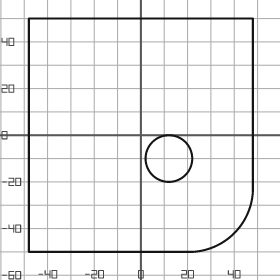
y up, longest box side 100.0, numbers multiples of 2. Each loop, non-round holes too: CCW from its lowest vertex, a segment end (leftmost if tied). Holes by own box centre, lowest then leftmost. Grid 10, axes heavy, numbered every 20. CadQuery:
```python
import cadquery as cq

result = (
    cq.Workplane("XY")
    .moveTo(-48.0, -50.0)
    .lineTo(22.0, -50.0)
    .threePointArc((40.0, -42.0), (48.0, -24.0))
    .lineTo(48.0, 50.0)
    .lineTo(-48.0, 50.0)
    .close()
    .moveTo(12.0, -10.0)
    .circle(10.0)
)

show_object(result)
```